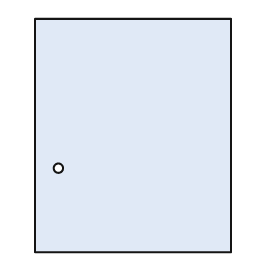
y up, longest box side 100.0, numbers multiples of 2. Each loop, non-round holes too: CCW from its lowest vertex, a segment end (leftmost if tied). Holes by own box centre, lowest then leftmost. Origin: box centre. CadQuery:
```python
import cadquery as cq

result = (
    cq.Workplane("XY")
    .moveTo(-42.0, -50.0)
    .lineTo(42.0, -50.0)
    .lineTo(42.0, 50.0)
    .lineTo(-42.0, 50.0)
    .close()
    .moveTo(-32.0, -14.0)
    .circle(2.0)
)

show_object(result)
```